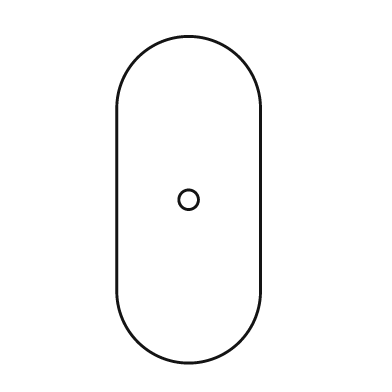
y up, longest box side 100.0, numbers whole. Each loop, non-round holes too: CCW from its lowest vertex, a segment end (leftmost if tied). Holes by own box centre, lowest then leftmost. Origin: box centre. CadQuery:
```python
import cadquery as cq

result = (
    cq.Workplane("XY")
    .moveTo(-22.0, -28.0)
    .threePointArc((0.0, -50.0), (22.0, -28.0))
    .lineTo(22.0, 28.0)
    .threePointArc((0.0, 50.0), (-22.0, 28.0))
    .close()
    .moveTo(0.0, 0.0)
    .circle(3.0)
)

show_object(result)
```